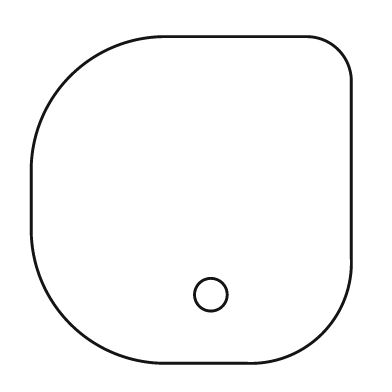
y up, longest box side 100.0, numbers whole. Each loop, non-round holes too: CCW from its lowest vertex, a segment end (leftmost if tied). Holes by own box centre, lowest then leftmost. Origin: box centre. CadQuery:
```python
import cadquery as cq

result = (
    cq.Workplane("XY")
    .moveTo(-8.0, -50.0)
    .lineTo(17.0, -50.0)
    .threePointArc((40.0, -41.0), (49.0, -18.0))
    .lineTo(49.0, 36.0)
    .threePointArc((45.0, 46.0), (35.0, 50.0))
    .lineTo(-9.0, 50.0)
    .threePointArc((-37.0, 38.0), (-49.0, 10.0))
    .lineTo(-49.0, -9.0)
    .threePointArc((-37.0, -38.0), (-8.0, -50.0))
    .close()
    .moveTo(6.0, -29.0)
    .circle(5.0)
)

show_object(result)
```